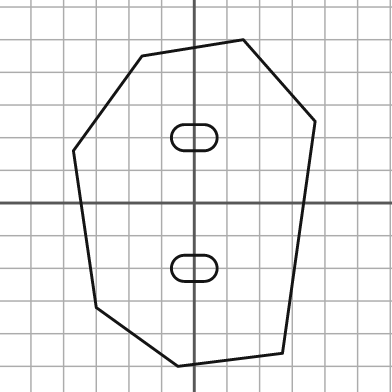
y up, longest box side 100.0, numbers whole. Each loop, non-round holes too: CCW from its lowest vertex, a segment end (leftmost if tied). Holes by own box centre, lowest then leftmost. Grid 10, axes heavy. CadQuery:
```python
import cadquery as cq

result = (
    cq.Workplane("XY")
    .moveTo(-5.0, -50.0)
    .lineTo(27.0, -46.0)
    .lineTo(37.0, 25.0)
    .lineTo(15.0, 50.0)
    .lineTo(-16.0, 45.0)
    .lineTo(-37.0, 16.0)
    .lineTo(-30.0, -32.0)
    .close()
    .moveTo(-3.0, -24.0)
    .lineTo(3.0, -24.0)
    .threePointArc((7.0, -20.0), (3.0, -16.0))
    .lineTo(-3.0, -16.0)
    .threePointArc((-7.0, -20.0), (-3.0, -24.0))
    .close()
    .moveTo(-3.0, 16.0)
    .lineTo(3.0, 16.0)
    .threePointArc((7.0, 20.0), (3.0, 24.0))
    .lineTo(-3.0, 24.0)
    .threePointArc((-7.0, 20.0), (-3.0, 16.0))
    .close()
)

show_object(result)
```